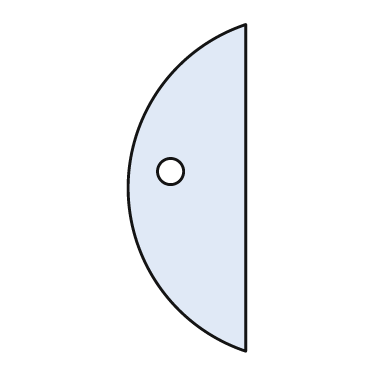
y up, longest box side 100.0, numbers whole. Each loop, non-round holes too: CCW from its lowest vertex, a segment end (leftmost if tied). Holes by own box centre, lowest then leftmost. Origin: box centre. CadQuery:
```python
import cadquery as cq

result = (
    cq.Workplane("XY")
    .moveTo(18.0, -50.0)
    .lineTo(18.0, 50.0)
    .threePointArc((-18.0, 0.0), (18.0, -50.0))
    .close()
    .moveTo(-5.0, 5.0)
    .circle(4.0)
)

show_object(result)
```